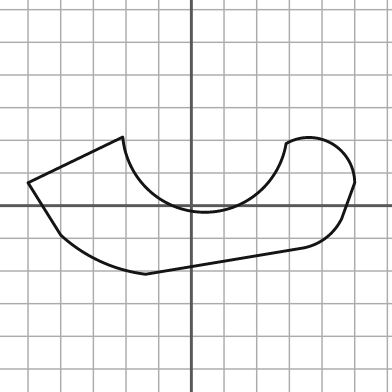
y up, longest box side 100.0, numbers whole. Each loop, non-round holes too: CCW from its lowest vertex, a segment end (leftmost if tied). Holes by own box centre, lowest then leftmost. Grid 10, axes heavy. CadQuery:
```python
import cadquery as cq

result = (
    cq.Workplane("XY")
    .moveTo(-14.0, -21.0)
    .lineTo(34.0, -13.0)
    .threePointArc((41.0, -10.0), (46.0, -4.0))
    .lineTo(50.0, 7.0)
    .threePointArc((43.0, 19.0), (29.0, 19.0))
    .threePointArc((3.0, -2.0), (-21.0, 21.0))
    .lineTo(-50.0, 7.0)
    .lineTo(-40.0, -9.0)
    .threePointArc((-28.0, -17.0), (-14.0, -21.0))
    .close()
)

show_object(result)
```